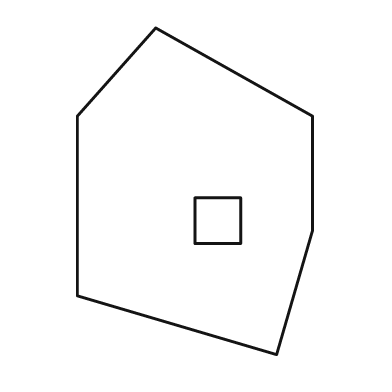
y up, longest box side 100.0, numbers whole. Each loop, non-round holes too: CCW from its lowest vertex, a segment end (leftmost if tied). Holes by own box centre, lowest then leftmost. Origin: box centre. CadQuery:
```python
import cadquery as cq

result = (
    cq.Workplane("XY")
    .moveTo(25.0, -50.0)
    .lineTo(36.0, -12.0)
    .lineTo(36.0, 23.0)
    .lineTo(-12.0, 50.0)
    .lineTo(-36.0, 23.0)
    .lineTo(-36.0, -32.0)
    .close()
    .moveTo(0.0, -16.0)
    .lineTo(14.0, -16.0)
    .lineTo(14.0, -2.0)
    .lineTo(0.0, -2.0)
    .close()
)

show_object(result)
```